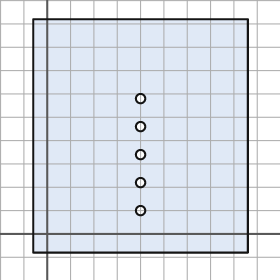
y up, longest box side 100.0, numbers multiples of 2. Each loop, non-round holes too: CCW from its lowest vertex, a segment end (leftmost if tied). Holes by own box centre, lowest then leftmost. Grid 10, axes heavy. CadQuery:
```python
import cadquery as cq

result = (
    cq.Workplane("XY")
    .moveTo(-6.0, -8.0)
    .lineTo(86.0, -8.0)
    .lineTo(86.0, 92.0)
    .lineTo(-6.0, 92.0)
    .close()
    .moveTo(40.0, 10.0)
    .circle(2.0)
    .moveTo(40.0, 22.0)
    .circle(2.0)
    .moveTo(40.0, 34.0)
    .circle(2.0)
    .moveTo(40.0, 46.0)
    .circle(2.0)
    .moveTo(40.0, 58.0)
    .circle(2.0)
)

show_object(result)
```